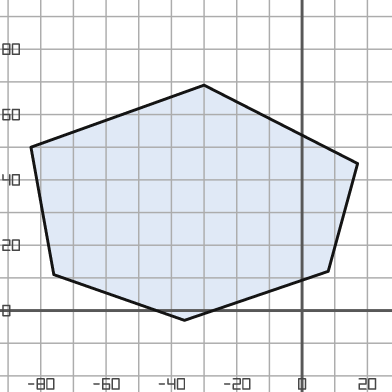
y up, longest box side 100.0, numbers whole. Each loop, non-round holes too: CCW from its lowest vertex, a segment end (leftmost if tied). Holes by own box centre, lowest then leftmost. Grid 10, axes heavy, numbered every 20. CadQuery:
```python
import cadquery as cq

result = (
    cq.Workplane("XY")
    .moveTo(-36.0, -3.0)
    .lineTo(8.0, 12.0)
    .lineTo(17.0, 45.0)
    .lineTo(-30.0, 69.0)
    .lineTo(-83.0, 50.0)
    .lineTo(-76.0, 11.0)
    .close()
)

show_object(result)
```